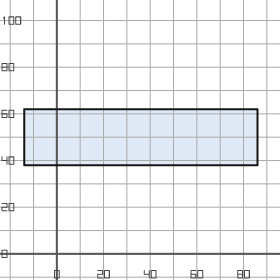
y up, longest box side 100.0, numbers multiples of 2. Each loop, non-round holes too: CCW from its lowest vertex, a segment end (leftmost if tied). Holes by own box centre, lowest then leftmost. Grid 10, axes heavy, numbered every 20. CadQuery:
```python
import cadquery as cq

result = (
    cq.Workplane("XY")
    .moveTo(-14.0, 38.0)
    .lineTo(86.0, 38.0)
    .lineTo(86.0, 62.0)
    .lineTo(-14.0, 62.0)
    .close()
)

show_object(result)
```